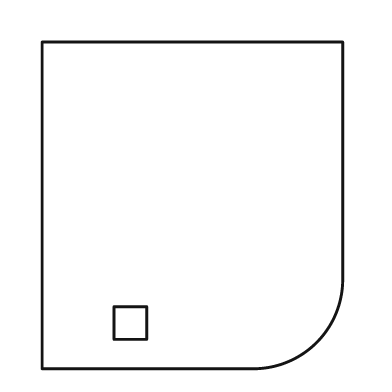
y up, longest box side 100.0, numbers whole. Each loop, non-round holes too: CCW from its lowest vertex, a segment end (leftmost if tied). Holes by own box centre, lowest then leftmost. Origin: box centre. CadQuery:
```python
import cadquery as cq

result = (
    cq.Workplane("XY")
    .moveTo(-46.0, -50.0)
    .lineTo(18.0, -50.0)
    .threePointArc((38.0, -42.0), (46.0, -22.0))
    .lineTo(46.0, 50.0)
    .lineTo(-46.0, 50.0)
    .close()
    .moveTo(-24.0, -41.0)
    .lineTo(-14.0, -41.0)
    .lineTo(-14.0, -31.0)
    .lineTo(-24.0, -31.0)
    .close()
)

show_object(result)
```